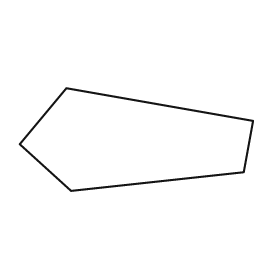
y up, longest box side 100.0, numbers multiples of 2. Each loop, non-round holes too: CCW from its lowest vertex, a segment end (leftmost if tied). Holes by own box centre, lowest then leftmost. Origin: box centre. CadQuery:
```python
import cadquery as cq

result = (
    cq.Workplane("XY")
    .moveTo(-28.0, -22.0)
    .lineTo(46.0, -14.0)
    .lineTo(50.0, 8.0)
    .lineTo(-30.0, 22.0)
    .lineTo(-50.0, -2.0)
    .close()
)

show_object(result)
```